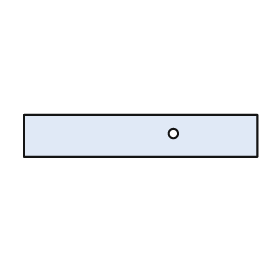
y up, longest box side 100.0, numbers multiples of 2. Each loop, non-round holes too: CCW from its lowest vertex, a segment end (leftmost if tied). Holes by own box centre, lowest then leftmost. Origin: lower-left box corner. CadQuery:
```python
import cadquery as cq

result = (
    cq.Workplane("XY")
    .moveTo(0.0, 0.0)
    .lineTo(100.0, 0.0)
    .lineTo(100.0, 18.0)
    .lineTo(0.0, 18.0)
    .close()
    .moveTo(64.0, 10.0)
    .circle(2.0)
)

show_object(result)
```